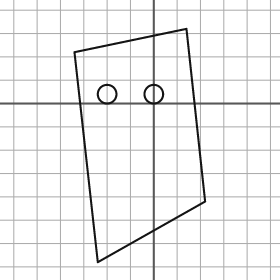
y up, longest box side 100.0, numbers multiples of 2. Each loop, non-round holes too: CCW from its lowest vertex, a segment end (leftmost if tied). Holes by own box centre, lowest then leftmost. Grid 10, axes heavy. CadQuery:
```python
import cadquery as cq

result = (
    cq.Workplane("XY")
    .moveTo(-24.0, -68.0)
    .lineTo(22.0, -42.0)
    .lineTo(14.0, 32.0)
    .lineTo(-34.0, 22.0)
    .close()
    .moveTo(-20.0, 4.0)
    .circle(4.0)
    .moveTo(0.0, 4.0)
    .circle(4.0)
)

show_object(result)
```